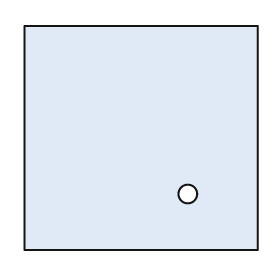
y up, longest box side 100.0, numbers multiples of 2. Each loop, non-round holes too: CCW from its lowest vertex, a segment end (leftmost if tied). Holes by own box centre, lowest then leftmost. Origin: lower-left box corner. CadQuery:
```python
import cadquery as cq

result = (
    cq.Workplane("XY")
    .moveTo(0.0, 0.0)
    .lineTo(100.0, 0.0)
    .lineTo(100.0, 96.0)
    .lineTo(0.0, 96.0)
    .close()
    .moveTo(70.0, 24.0)
    .circle(4.0)
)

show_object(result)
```